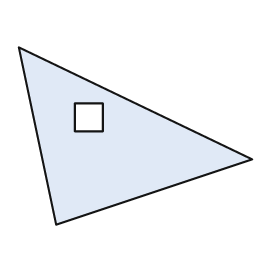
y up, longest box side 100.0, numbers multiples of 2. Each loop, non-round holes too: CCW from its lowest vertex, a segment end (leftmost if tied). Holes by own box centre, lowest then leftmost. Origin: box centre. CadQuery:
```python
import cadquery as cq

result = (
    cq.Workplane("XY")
    .moveTo(-34.0, -38.0)
    .lineTo(50.0, -10.0)
    .lineTo(-50.0, 38.0)
    .close()
    .moveTo(-26.0, 2.0)
    .lineTo(-14.0, 2.0)
    .lineTo(-14.0, 14.0)
    .lineTo(-26.0, 14.0)
    .close()
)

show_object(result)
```